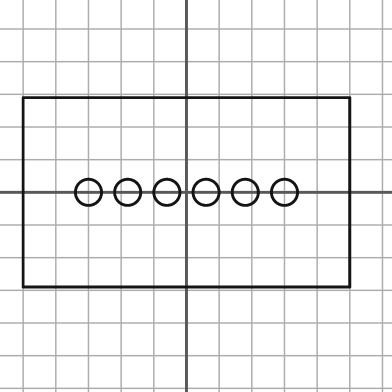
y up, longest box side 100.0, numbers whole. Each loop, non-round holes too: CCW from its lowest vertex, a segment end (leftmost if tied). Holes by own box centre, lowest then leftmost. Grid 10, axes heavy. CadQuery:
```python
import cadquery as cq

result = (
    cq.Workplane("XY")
    .moveTo(-50.0, -29.0)
    .lineTo(50.0, -29.0)
    .lineTo(50.0, 29.0)
    .lineTo(-50.0, 29.0)
    .close()
    .moveTo(-30.0, 0.0)
    .circle(4.0)
    .moveTo(-18.0, 0.0)
    .circle(4.0)
    .moveTo(-6.0, 0.0)
    .circle(4.0)
    .moveTo(6.0, 0.0)
    .circle(4.0)
    .moveTo(18.0, 0.0)
    .circle(4.0)
    .moveTo(30.0, 0.0)
    .circle(4.0)
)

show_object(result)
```